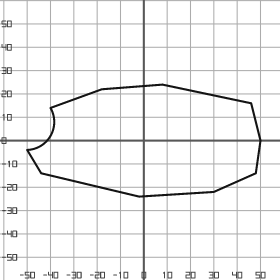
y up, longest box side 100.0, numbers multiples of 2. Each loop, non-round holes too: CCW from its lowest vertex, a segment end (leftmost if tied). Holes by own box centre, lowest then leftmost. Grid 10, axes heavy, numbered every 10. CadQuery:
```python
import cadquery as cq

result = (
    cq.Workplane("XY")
    .moveTo(-2.0, -24.0)
    .lineTo(30.0, -22.0)
    .lineTo(48.0, -14.0)
    .lineTo(50.0, 0.0)
    .lineTo(46.0, 16.0)
    .lineTo(8.0, 24.0)
    .lineTo(-18.0, 22.0)
    .lineTo(-40.0, 14.0)
    .threePointArc((-40.0, 2.0), (-50.0, -4.0))
    .lineTo(-44.0, -14.0)
    .close()
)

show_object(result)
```